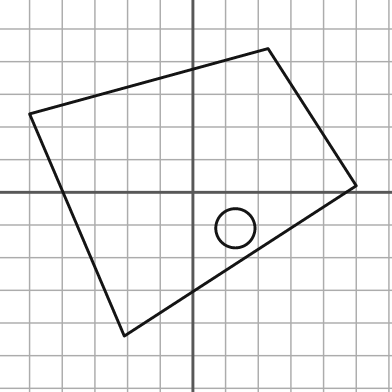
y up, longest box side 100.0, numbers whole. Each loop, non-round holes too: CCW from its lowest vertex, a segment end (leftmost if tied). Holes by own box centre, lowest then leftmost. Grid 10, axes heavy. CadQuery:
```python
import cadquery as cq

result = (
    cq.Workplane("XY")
    .moveTo(-21.0, -44.0)
    .lineTo(50.0, 2.0)
    .lineTo(23.0, 44.0)
    .lineTo(-50.0, 24.0)
    .close()
    .moveTo(13.0, -11.0)
    .circle(6.0)
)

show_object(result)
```